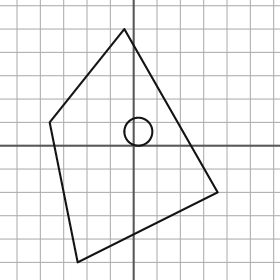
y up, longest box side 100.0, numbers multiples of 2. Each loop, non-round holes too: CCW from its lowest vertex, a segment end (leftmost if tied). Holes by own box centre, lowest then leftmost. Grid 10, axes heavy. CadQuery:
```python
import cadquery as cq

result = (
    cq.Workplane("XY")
    .moveTo(-24.0, -50.0)
    .lineTo(36.0, -20.0)
    .lineTo(-4.0, 50.0)
    .lineTo(-36.0, 10.0)
    .close()
    .moveTo(2.0, 6.0)
    .circle(6.0)
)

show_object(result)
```